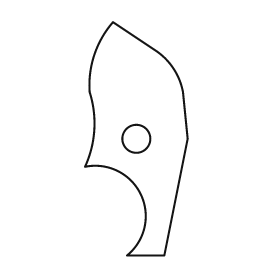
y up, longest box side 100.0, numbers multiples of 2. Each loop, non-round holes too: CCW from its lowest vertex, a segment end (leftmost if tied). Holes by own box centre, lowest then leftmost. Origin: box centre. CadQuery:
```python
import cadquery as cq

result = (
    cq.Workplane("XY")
    .moveTo(-4.0, -50.0)
    .lineTo(12.0, -50.0)
    .lineTo(22.0, 0.0)
    .lineTo(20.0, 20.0)
    .threePointArc((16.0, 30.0), (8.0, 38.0))
    .lineTo(-10.0, 50.0)
    .threePointArc((-18.0, 36.0), (-20.0, 20.0))
    .threePointArc((-18.0, 4.0), (-22.0, -12.0))
    .threePointArc((2.0, -24.0), (-4.0, -50.0))
    .close()
    .moveTo(0.0, 0.0)
    .circle(6.0)
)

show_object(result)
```